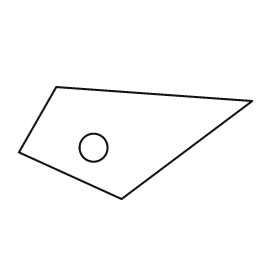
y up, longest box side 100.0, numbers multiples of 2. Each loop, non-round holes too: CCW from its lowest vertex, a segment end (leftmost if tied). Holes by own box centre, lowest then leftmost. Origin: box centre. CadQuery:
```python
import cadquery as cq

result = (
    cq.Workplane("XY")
    .moveTo(-6.0, -24.0)
    .lineTo(50.0, 18.0)
    .lineTo(-34.0, 24.0)
    .lineTo(-50.0, -4.0)
    .close()
    .moveTo(-18.0, -2.0)
    .circle(6.0)
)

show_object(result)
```